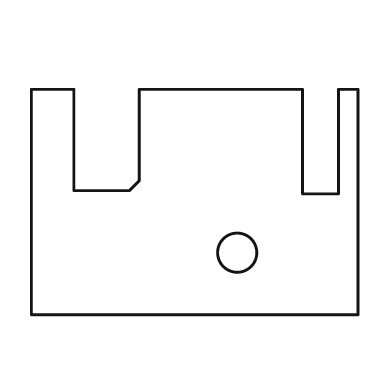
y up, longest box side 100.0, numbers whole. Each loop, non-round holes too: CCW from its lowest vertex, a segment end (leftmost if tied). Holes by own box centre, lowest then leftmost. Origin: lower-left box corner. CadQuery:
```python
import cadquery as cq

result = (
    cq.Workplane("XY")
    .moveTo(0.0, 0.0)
    .lineTo(100.0, 0.0)
    .lineTo(100.0, 69.0)
    .lineTo(94.0, 69.0)
    .lineTo(94.0, 37.0)
    .lineTo(83.0, 37.0)
    .lineTo(83.0, 69.0)
    .lineTo(33.0, 69.0)
    .lineTo(33.0, 41.0)
    .lineTo(30.0, 38.0)
    .lineTo(13.0, 38.0)
    .lineTo(13.0, 69.0)
    .lineTo(0.0, 69.0)
    .close()
    .moveTo(63.0, 19.0)
    .circle(6.0)
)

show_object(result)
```